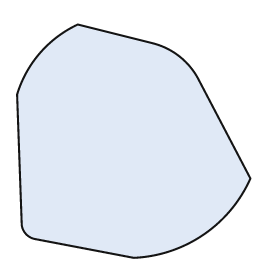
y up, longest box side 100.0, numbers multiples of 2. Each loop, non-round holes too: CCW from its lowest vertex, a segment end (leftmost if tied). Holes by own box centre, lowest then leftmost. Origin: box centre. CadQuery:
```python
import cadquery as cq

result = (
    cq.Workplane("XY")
    .moveTo(0.0, -50.0)
    .threePointArc((30.0, -40.0), (50.0, -16.0))
    .lineTo(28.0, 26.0)
    .threePointArc((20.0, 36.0), (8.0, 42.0))
    .lineTo(-24.0, 50.0)
    .threePointArc((-40.0, 38.0), (-50.0, 20.0))
    .lineTo(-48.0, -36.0)
    .threePointArc((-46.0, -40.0), (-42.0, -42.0))
    .close()
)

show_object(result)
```